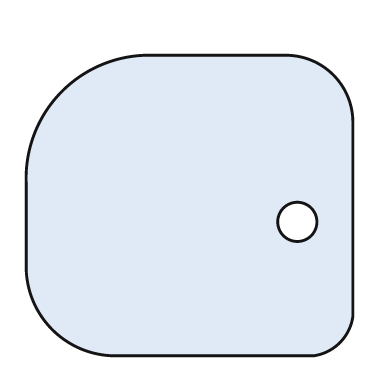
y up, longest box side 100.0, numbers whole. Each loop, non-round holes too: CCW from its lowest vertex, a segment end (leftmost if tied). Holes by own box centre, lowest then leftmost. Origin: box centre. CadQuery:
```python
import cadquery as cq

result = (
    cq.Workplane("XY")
    .moveTo(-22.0, -46.0)
    .lineTo(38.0, -46.0)
    .threePointArc((46.0, -42.0), (50.0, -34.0))
    .lineTo(50.0, 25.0)
    .threePointArc((44.0, 40.0), (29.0, 46.0))
    .lineTo(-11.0, 46.0)
    .threePointArc((-39.0, 35.0), (-50.0, 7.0))
    .lineTo(-50.0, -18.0)
    .threePointArc((-42.0, -38.0), (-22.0, -46.0))
    .close()
    .moveTo(33.0, -5.0)
    .circle(6.0)
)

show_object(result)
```